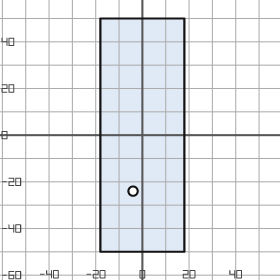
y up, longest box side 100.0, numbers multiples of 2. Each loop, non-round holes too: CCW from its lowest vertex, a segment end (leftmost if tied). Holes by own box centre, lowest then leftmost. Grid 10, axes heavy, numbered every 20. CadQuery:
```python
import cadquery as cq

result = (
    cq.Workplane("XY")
    .moveTo(-18.0, -50.0)
    .lineTo(18.0, -50.0)
    .lineTo(18.0, 50.0)
    .lineTo(-18.0, 50.0)
    .close()
    .moveTo(-4.0, -24.0)
    .circle(2.0)
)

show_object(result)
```